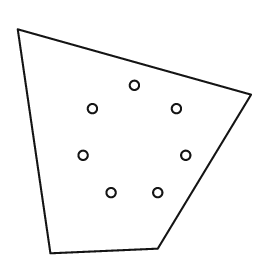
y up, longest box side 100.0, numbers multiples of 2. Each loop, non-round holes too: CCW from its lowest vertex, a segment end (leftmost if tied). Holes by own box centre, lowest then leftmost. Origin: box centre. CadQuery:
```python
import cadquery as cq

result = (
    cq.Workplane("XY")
    .moveTo(-36.0, -48.0)
    .lineTo(10.0, -46.0)
    .lineTo(50.0, 20.0)
    .lineTo(-50.0, 48.0)
    .close()
    .moveTo(-10.0, -22.0)
    .circle(2.0)
    .moveTo(10.0, -22.0)
    .circle(2.0)
    .moveTo(-22.0, -6.0)
    .circle(2.0)
    .moveTo(22.0, -6.0)
    .circle(2.0)
    .moveTo(-18.0, 14.0)
    .circle(2.0)
    .moveTo(18.0, 14.0)
    .circle(2.0)
    .moveTo(0.0, 24.0)
    .circle(2.0)
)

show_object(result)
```